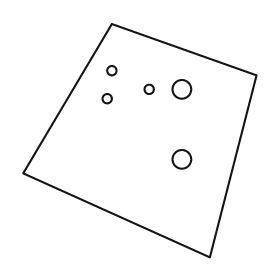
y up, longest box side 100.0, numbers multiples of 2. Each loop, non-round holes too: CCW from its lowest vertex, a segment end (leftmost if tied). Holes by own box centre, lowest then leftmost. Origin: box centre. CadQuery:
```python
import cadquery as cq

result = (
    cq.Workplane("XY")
    .moveTo(30.0, -50.0)
    .lineTo(50.0, 28.0)
    .lineTo(-12.0, 50.0)
    .lineTo(-50.0, -14.0)
    .close()
    .moveTo(18.0, -8.0)
    .circle(4.0)
    .moveTo(-14.0, 18.0)
    .circle(2.0)
    .moveTo(4.0, 22.0)
    .circle(2.0)
    .moveTo(18.0, 22.0)
    .circle(4.0)
    .moveTo(-12.0, 30.0)
    .circle(2.0)
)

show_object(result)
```